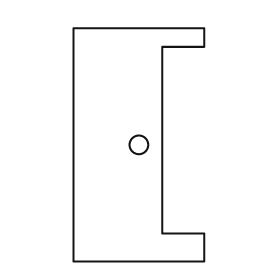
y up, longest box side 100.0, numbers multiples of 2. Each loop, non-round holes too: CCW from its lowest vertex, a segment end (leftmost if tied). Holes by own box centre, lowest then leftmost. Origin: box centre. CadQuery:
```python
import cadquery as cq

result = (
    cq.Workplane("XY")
    .moveTo(-28.0, -50.0)
    .lineTo(28.0, -50.0)
    .lineTo(28.0, -38.0)
    .lineTo(10.0, -38.0)
    .lineTo(10.0, 42.0)
    .lineTo(28.0, 42.0)
    .lineTo(28.0, 50.0)
    .lineTo(-28.0, 50.0)
    .close()
    .moveTo(0.0, 0.0)
    .circle(4.0)
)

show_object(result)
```